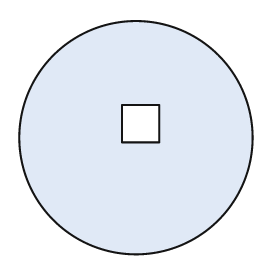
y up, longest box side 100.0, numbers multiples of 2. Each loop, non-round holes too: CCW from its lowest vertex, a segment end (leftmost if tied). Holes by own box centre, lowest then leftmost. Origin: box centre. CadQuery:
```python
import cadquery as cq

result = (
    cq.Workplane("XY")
    .moveTo(0.0, 0.0)
    .circle(50.0)
    .moveTo(-6.0, -2.0)
    .lineTo(10.0, -2.0)
    .lineTo(10.0, 14.0)
    .lineTo(-6.0, 14.0)
    .close()
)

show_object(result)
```